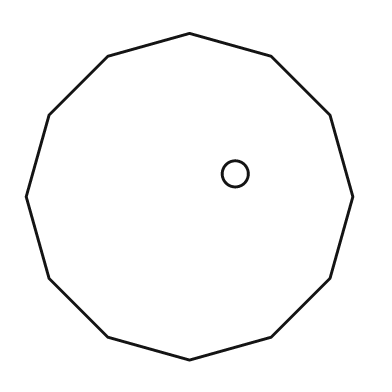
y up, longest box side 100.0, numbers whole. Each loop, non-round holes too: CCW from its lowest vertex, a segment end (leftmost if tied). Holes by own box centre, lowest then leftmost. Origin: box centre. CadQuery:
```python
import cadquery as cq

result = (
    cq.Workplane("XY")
    .moveTo(0.0, -50.0)
    .lineTo(25.0, -43.0)
    .lineTo(43.0, -25.0)
    .lineTo(50.0, 0.0)
    .lineTo(43.0, 25.0)
    .lineTo(25.0, 43.0)
    .lineTo(0.0, 50.0)
    .lineTo(-25.0, 43.0)
    .lineTo(-43.0, 25.0)
    .lineTo(-50.0, 0.0)
    .lineTo(-43.0, -25.0)
    .lineTo(-25.0, -43.0)
    .close()
    .moveTo(14.0, 7.0)
    .circle(4.0)
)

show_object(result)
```